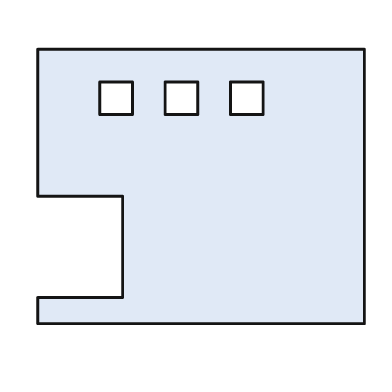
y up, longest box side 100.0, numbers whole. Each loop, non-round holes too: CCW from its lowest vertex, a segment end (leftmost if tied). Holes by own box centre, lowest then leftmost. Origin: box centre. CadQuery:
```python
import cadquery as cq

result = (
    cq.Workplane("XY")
    .moveTo(-50.0, -42.0)
    .lineTo(50.0, -42.0)
    .lineTo(50.0, 42.0)
    .lineTo(-50.0, 42.0)
    .lineTo(-50.0, -3.0)
    .lineTo(-24.0, -3.0)
    .lineTo(-24.0, -34.0)
    .lineTo(-50.0, -34.0)
    .close()
    .moveTo(-31.0, 22.0)
    .lineTo(-21.0, 22.0)
    .lineTo(-21.0, 32.0)
    .lineTo(-31.0, 32.0)
    .close()
    .moveTo(-11.0, 22.0)
    .lineTo(-1.0, 22.0)
    .lineTo(-1.0, 32.0)
    .lineTo(-11.0, 32.0)
    .close()
    .moveTo(9.0, 22.0)
    .lineTo(19.0, 22.0)
    .lineTo(19.0, 32.0)
    .lineTo(9.0, 32.0)
    .close()
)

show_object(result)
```